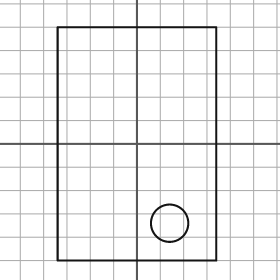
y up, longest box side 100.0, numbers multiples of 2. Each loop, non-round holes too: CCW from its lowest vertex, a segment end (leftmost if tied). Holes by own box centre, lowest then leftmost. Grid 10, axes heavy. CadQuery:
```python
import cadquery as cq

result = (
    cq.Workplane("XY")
    .moveTo(-34.0, -50.0)
    .lineTo(34.0, -50.0)
    .lineTo(34.0, 50.0)
    .lineTo(-34.0, 50.0)
    .close()
    .moveTo(14.0, -34.0)
    .circle(8.0)
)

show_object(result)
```